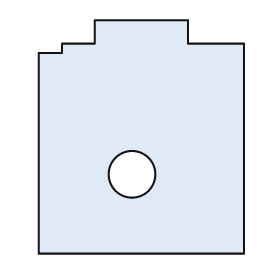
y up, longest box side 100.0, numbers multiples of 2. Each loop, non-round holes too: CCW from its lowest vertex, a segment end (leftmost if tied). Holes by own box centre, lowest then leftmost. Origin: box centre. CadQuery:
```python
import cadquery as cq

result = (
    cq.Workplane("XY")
    .moveTo(-44.0, -50.0)
    .lineTo(44.0, -50.0)
    .lineTo(44.0, 40.0)
    .lineTo(20.0, 40.0)
    .lineTo(20.0, 50.0)
    .lineTo(-20.0, 50.0)
    .lineTo(-20.0, 40.0)
    .lineTo(-34.0, 40.0)
    .lineTo(-34.0, 36.0)
    .lineTo(-44.0, 36.0)
    .close()
    .moveTo(-4.0, -16.0)
    .circle(10.0)
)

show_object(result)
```